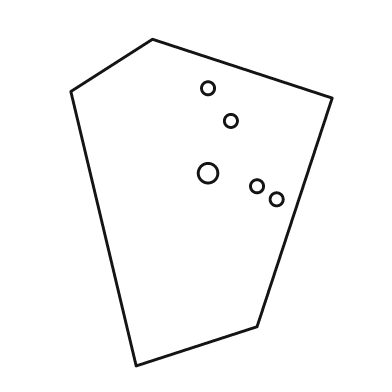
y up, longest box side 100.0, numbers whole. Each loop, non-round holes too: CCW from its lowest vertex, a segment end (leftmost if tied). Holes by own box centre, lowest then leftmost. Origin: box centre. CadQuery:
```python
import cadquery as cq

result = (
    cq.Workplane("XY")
    .moveTo(-20.0, -50.0)
    .lineTo(17.0, -38.0)
    .lineTo(40.0, 32.0)
    .lineTo(-15.0, 50.0)
    .lineTo(-40.0, 34.0)
    .close()
    .moveTo(23.0, 1.0)
    .circle(2.0)
    .moveTo(17.0, 5.0)
    .circle(2.0)
    .moveTo(2.0, 9.0)
    .circle(3.0)
    .moveTo(9.0, 25.0)
    .circle(2.0)
    .moveTo(2.0, 35.0)
    .circle(2.0)
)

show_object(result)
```